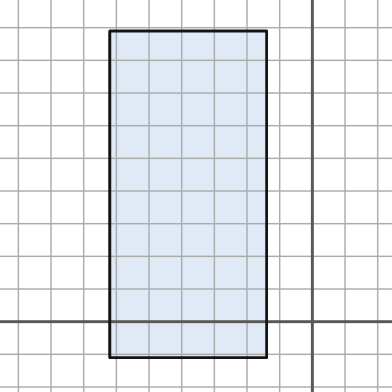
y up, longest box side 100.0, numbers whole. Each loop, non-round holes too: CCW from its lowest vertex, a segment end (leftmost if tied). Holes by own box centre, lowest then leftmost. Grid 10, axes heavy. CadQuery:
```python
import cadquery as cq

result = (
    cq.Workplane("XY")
    .moveTo(-62.0, -11.0)
    .lineTo(-14.0, -11.0)
    .lineTo(-14.0, 89.0)
    .lineTo(-62.0, 89.0)
    .close()
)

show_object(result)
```